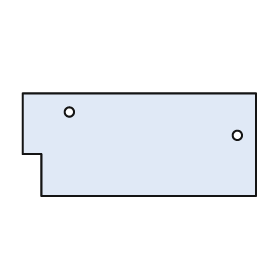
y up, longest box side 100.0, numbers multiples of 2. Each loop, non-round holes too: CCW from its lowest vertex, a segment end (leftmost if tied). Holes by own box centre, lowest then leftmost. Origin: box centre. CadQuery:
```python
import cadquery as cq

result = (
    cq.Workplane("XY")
    .moveTo(-42.0, -22.0)
    .lineTo(50.0, -22.0)
    .lineTo(50.0, 22.0)
    .lineTo(-50.0, 22.0)
    .lineTo(-50.0, -4.0)
    .lineTo(-42.0, -4.0)
    .close()
    .moveTo(42.0, 4.0)
    .circle(2.0)
    .moveTo(-30.0, 14.0)
    .circle(2.0)
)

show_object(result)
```